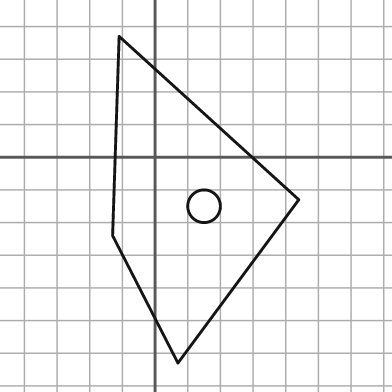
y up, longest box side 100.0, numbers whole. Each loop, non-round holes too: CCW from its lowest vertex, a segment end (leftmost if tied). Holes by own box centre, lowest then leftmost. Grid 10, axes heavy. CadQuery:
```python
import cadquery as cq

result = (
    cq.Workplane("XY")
    .moveTo(7.0, -63.0)
    .lineTo(44.0, -13.0)
    .lineTo(-11.0, 37.0)
    .lineTo(-13.0, -24.0)
    .close()
    .moveTo(15.0, -15.0)
    .circle(5.0)
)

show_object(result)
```